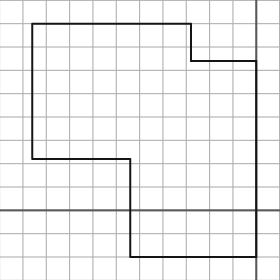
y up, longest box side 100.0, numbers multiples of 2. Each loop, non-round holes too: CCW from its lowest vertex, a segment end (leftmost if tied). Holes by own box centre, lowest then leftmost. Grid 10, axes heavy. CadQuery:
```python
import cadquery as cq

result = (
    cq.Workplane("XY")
    .moveTo(-54.0, -20.0)
    .lineTo(0.0, -20.0)
    .lineTo(0.0, 64.0)
    .lineTo(-28.0, 64.0)
    .lineTo(-28.0, 80.0)
    .lineTo(-96.0, 80.0)
    .lineTo(-96.0, 22.0)
    .lineTo(-54.0, 22.0)
    .close()
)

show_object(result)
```